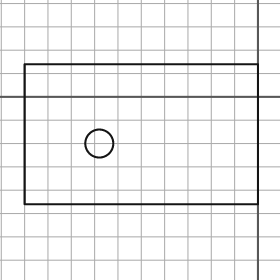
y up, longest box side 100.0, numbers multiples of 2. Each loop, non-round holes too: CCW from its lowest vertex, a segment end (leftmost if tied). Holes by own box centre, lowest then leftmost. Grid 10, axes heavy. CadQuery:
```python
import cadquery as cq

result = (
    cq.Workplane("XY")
    .moveTo(-100.0, -46.0)
    .lineTo(0.0, -46.0)
    .lineTo(0.0, 14.0)
    .lineTo(-100.0, 14.0)
    .close()
    .moveTo(-68.0, -20.0)
    .circle(6.0)
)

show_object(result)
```